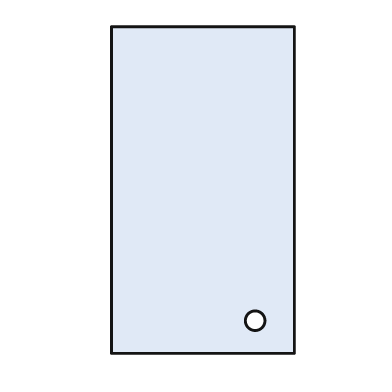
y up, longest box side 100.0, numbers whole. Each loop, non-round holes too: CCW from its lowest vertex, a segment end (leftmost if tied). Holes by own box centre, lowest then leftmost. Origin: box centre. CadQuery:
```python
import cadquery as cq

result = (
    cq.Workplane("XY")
    .moveTo(-28.0, -50.0)
    .lineTo(28.0, -50.0)
    .lineTo(28.0, 50.0)
    .lineTo(-28.0, 50.0)
    .close()
    .moveTo(16.0, -40.0)
    .circle(3.0)
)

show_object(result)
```